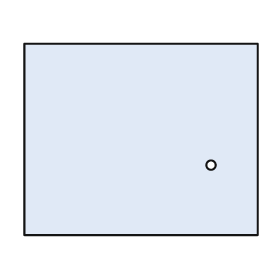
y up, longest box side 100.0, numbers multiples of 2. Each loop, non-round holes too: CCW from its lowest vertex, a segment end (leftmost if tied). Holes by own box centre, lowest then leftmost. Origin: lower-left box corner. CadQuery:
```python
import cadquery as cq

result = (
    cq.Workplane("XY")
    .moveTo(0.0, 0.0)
    .lineTo(100.0, 0.0)
    .lineTo(100.0, 82.0)
    .lineTo(0.0, 82.0)
    .close()
    .moveTo(80.0, 30.0)
    .circle(2.0)
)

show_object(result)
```